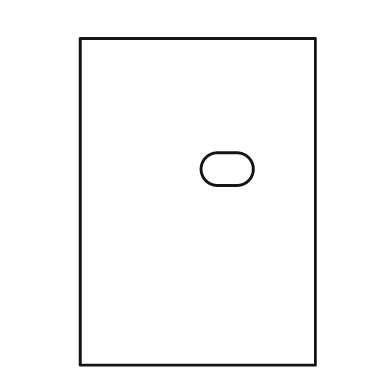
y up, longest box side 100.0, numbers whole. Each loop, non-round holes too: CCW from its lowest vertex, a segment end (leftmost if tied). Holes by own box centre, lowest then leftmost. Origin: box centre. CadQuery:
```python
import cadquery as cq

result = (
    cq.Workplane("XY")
    .moveTo(-36.0, -50.0)
    .lineTo(36.0, -50.0)
    .lineTo(36.0, 50.0)
    .lineTo(-36.0, 50.0)
    .close()
    .moveTo(6.0, 5.0)
    .lineTo(12.0, 5.0)
    .threePointArc((17.0, 10.0), (12.0, 15.0))
    .lineTo(6.0, 15.0)
    .threePointArc((1.0, 10.0), (6.0, 5.0))
    .close()
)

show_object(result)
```